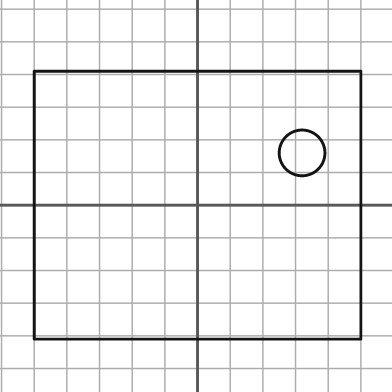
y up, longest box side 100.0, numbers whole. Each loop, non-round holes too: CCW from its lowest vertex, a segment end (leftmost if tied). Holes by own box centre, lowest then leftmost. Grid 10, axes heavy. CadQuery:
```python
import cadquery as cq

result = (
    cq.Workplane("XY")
    .moveTo(-50.0, -41.0)
    .lineTo(50.0, -41.0)
    .lineTo(50.0, 41.0)
    .lineTo(-50.0, 41.0)
    .close()
    .moveTo(32.0, 16.0)
    .circle(7.0)
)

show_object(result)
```